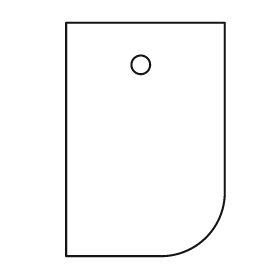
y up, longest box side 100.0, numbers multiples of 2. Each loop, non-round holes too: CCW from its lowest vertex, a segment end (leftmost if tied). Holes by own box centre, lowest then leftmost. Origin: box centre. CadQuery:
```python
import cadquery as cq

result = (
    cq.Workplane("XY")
    .moveTo(-34.0, -50.0)
    .lineTo(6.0, -50.0)
    .threePointArc((26.0, -42.0), (34.0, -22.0))
    .lineTo(34.0, 50.0)
    .lineTo(-34.0, 50.0)
    .close()
    .moveTo(-2.0, 32.0)
    .circle(4.0)
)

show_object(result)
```